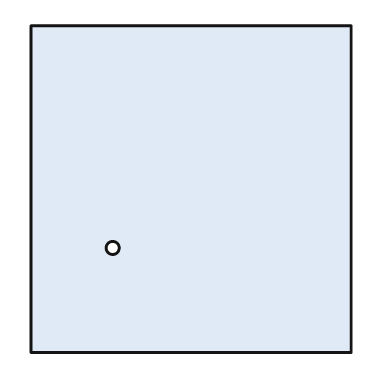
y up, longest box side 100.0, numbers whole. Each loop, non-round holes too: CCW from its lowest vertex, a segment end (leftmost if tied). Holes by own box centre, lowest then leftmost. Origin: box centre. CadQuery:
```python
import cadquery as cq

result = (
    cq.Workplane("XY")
    .moveTo(-49.0, -50.0)
    .lineTo(49.0, -50.0)
    .lineTo(49.0, 50.0)
    .lineTo(-49.0, 50.0)
    .close()
    .moveTo(-24.0, -18.0)
    .circle(2.0)
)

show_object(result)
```